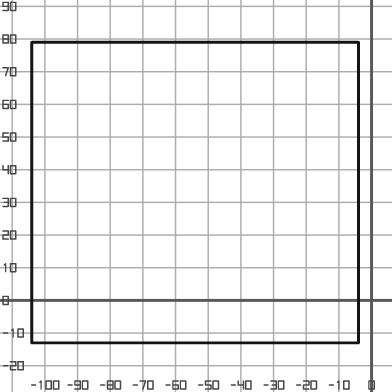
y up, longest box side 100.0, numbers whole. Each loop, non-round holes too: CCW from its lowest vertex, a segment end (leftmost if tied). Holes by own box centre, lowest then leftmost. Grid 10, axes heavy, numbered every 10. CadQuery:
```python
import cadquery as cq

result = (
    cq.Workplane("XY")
    .moveTo(-104.0, -13.0)
    .lineTo(-4.0, -13.0)
    .lineTo(-4.0, 79.0)
    .lineTo(-104.0, 79.0)
    .close()
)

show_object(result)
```